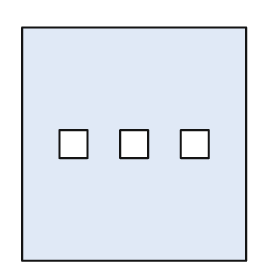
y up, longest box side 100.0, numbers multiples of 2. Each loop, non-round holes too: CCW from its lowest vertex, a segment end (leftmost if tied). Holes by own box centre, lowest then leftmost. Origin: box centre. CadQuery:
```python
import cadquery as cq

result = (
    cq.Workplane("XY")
    .moveTo(-48.0, -50.0)
    .lineTo(48.0, -50.0)
    .lineTo(48.0, 50.0)
    .lineTo(-48.0, 50.0)
    .close()
    .moveTo(-32.0, -6.0)
    .lineTo(-20.0, -6.0)
    .lineTo(-20.0, 6.0)
    .lineTo(-32.0, 6.0)
    .close()
    .moveTo(-6.0, -6.0)
    .lineTo(6.0, -6.0)
    .lineTo(6.0, 6.0)
    .lineTo(-6.0, 6.0)
    .close()
    .moveTo(20.0, -6.0)
    .lineTo(32.0, -6.0)
    .lineTo(32.0, 6.0)
    .lineTo(20.0, 6.0)
    .close()
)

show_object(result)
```